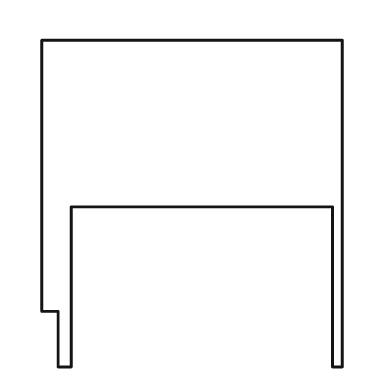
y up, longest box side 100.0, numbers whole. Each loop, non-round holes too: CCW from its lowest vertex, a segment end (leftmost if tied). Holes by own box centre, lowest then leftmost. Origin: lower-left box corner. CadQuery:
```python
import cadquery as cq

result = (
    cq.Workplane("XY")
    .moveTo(5.0, 0.0)
    .lineTo(9.0, 0.0)
    .lineTo(9.0, 49.0)
    .lineTo(89.0, 49.0)
    .lineTo(89.0, 0.0)
    .lineTo(92.0, 0.0)
    .lineTo(92.0, 100.0)
    .lineTo(0.0, 100.0)
    .lineTo(0.0, 17.0)
    .lineTo(5.0, 17.0)
    .close()
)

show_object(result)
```